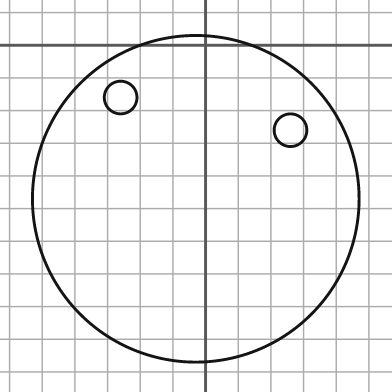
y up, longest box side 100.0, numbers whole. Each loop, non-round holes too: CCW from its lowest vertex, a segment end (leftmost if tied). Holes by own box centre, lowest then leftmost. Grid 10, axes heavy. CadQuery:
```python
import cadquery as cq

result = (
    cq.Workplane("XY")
    .moveTo(-3.0, -47.0)
    .circle(50.0)
    .moveTo(26.0, -26.0)
    .circle(5.0)
    .moveTo(-26.0, -16.0)
    .circle(5.0)
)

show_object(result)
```